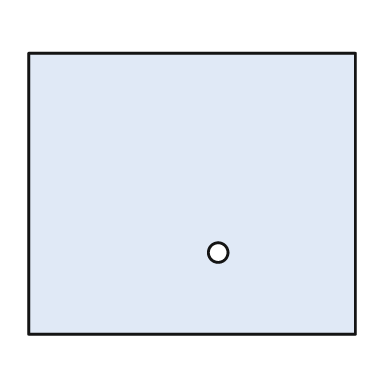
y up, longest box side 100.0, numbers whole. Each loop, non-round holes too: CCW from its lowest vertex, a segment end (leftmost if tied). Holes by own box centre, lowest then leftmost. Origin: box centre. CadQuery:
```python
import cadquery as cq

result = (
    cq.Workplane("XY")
    .moveTo(-50.0, -43.0)
    .lineTo(50.0, -43.0)
    .lineTo(50.0, 43.0)
    .lineTo(-50.0, 43.0)
    .close()
    .moveTo(8.0, -18.0)
    .circle(3.0)
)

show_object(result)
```